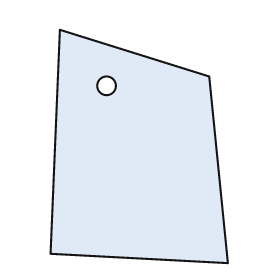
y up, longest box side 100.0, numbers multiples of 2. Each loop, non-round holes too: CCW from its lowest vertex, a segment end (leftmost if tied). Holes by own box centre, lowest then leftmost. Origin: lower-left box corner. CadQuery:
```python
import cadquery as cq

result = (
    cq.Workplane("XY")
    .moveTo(76.0, 0.0)
    .lineTo(68.0, 80.0)
    .lineTo(4.0, 100.0)
    .lineTo(0.0, 4.0)
    .close()
    .moveTo(24.0, 76.0)
    .circle(4.0)
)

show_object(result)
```